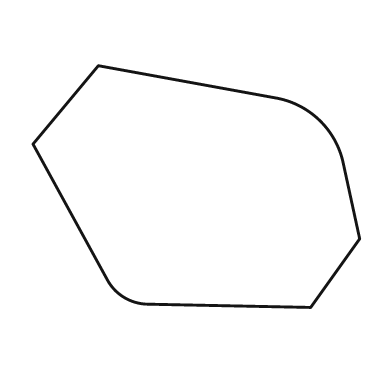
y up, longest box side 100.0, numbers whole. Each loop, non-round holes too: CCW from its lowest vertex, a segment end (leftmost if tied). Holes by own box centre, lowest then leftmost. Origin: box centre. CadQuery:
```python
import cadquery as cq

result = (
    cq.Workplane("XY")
    .moveTo(35.0, -37.0)
    .lineTo(50.0, -16.0)
    .lineTo(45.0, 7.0)
    .threePointArc((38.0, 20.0), (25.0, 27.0))
    .lineTo(-30.0, 37.0)
    .lineTo(-50.0, 13.0)
    .lineTo(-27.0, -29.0)
    .threePointArc((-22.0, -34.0), (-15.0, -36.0))
    .close()
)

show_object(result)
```